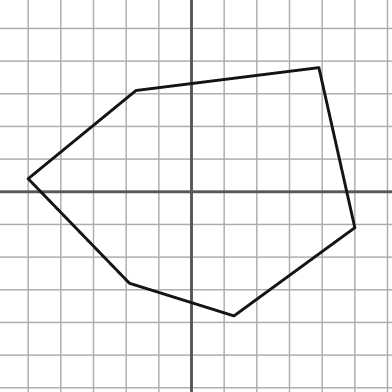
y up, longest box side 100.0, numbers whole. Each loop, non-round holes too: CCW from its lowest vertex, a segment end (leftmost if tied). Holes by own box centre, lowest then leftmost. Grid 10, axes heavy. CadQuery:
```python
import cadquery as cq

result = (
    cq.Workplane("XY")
    .moveTo(13.0, -38.0)
    .lineTo(50.0, -11.0)
    .lineTo(39.0, 38.0)
    .lineTo(-17.0, 31.0)
    .lineTo(-50.0, 4.0)
    .lineTo(-19.0, -28.0)
    .close()
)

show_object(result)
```